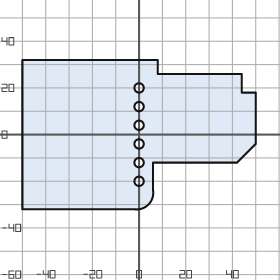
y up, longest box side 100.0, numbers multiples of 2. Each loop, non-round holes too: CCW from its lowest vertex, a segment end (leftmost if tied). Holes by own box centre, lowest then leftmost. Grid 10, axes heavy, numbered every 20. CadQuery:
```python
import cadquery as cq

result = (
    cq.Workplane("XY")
    .moveTo(-50.0, -32.0)
    .lineTo(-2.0, -32.0)
    .threePointArc((4.0, -30.0), (6.0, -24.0))
    .lineTo(6.0, -12.0)
    .lineTo(42.0, -12.0)
    .lineTo(50.0, -4.0)
    .lineTo(50.0, 18.0)
    .lineTo(44.0, 18.0)
    .lineTo(44.0, 26.0)
    .lineTo(8.0, 26.0)
    .lineTo(8.0, 32.0)
    .lineTo(-50.0, 32.0)
    .close()
    .moveTo(0.0, -20.0)
    .circle(2.0)
    .moveTo(0.0, -12.0)
    .circle(2.0)
    .moveTo(0.0, -4.0)
    .circle(2.0)
    .moveTo(0.0, 4.0)
    .circle(2.0)
    .moveTo(0.0, 12.0)
    .circle(2.0)
    .moveTo(0.0, 20.0)
    .circle(2.0)
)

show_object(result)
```